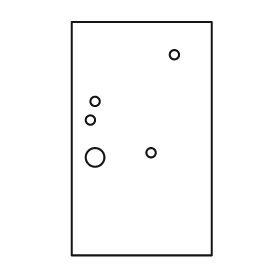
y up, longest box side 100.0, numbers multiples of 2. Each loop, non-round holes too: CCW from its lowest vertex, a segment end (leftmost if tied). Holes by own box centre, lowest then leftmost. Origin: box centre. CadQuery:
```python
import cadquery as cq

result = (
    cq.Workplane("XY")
    .moveTo(-30.0, -50.0)
    .lineTo(30.0, -50.0)
    .lineTo(30.0, 50.0)
    .lineTo(-30.0, 50.0)
    .close()
    .moveTo(-20.0, -8.0)
    .circle(4.0)
    .moveTo(4.0, -6.0)
    .circle(2.0)
    .moveTo(-22.0, 8.0)
    .circle(2.0)
    .moveTo(-20.0, 16.0)
    .circle(2.0)
    .moveTo(14.0, 36.0)
    .circle(2.0)
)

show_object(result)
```